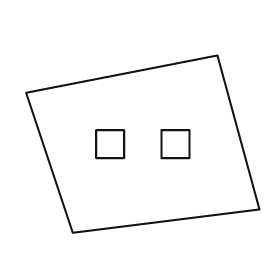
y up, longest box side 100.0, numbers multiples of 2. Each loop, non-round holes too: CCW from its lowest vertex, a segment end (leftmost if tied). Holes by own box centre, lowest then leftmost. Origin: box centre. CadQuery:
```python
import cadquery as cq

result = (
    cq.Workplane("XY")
    .moveTo(-30.0, -38.0)
    .lineTo(50.0, -28.0)
    .lineTo(32.0, 38.0)
    .lineTo(-50.0, 22.0)
    .close()
    .moveTo(-20.0, -6.0)
    .lineTo(-8.0, -6.0)
    .lineTo(-8.0, 6.0)
    .lineTo(-20.0, 6.0)
    .close()
    .moveTo(8.0, -6.0)
    .lineTo(20.0, -6.0)
    .lineTo(20.0, 6.0)
    .lineTo(8.0, 6.0)
    .close()
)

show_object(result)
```